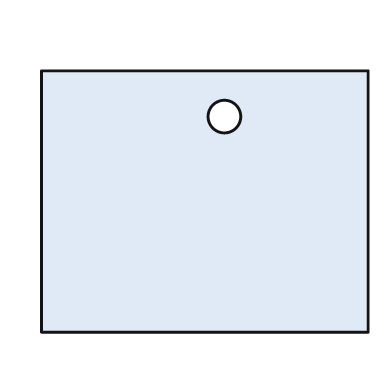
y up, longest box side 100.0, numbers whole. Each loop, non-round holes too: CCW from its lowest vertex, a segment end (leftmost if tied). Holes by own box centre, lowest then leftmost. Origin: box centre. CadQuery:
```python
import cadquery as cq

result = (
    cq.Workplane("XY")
    .moveTo(-50.0, -40.0)
    .lineTo(50.0, -40.0)
    .lineTo(50.0, 40.0)
    .lineTo(-50.0, 40.0)
    .close()
    .moveTo(6.0, 26.0)
    .circle(5.0)
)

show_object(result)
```